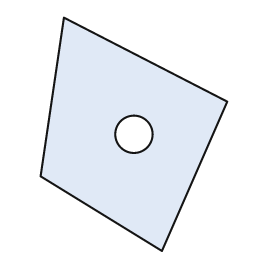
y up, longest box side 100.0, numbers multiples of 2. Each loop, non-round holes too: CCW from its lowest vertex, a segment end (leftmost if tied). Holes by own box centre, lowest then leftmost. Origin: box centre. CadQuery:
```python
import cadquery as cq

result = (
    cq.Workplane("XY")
    .moveTo(12.0, -50.0)
    .lineTo(40.0, 14.0)
    .lineTo(-30.0, 50.0)
    .lineTo(-40.0, -18.0)
    .close()
    .moveTo(0.0, 0.0)
    .circle(8.0)
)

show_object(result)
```